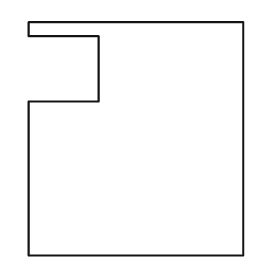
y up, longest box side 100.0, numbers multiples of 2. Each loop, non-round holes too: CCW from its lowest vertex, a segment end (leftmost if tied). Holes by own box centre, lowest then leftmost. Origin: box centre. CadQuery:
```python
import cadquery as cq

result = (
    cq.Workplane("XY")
    .moveTo(-46.0, -50.0)
    .lineTo(46.0, -50.0)
    .lineTo(46.0, 50.0)
    .lineTo(-46.0, 50.0)
    .lineTo(-46.0, 44.0)
    .lineTo(-16.0, 44.0)
    .lineTo(-16.0, 16.0)
    .lineTo(-46.0, 16.0)
    .close()
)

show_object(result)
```